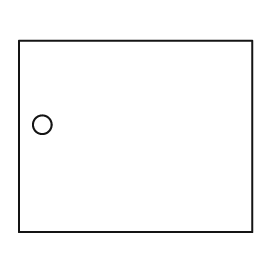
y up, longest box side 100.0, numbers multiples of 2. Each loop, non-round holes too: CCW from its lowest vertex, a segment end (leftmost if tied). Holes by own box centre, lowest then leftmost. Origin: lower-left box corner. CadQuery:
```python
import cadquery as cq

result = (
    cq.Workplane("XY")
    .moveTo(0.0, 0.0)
    .lineTo(100.0, 0.0)
    .lineTo(100.0, 82.0)
    .lineTo(0.0, 82.0)
    .close()
    .moveTo(10.0, 46.0)
    .circle(4.0)
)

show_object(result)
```